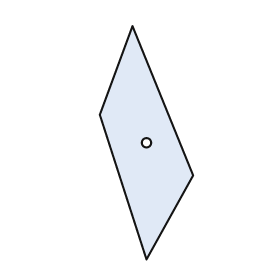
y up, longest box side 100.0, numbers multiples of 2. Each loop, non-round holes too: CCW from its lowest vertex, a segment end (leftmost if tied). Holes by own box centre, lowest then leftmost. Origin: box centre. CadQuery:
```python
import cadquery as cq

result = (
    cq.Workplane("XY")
    .moveTo(0.0, -50.0)
    .lineTo(20.0, -14.0)
    .lineTo(-6.0, 50.0)
    .lineTo(-20.0, 12.0)
    .close()
    .moveTo(0.0, 0.0)
    .circle(2.0)
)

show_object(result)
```